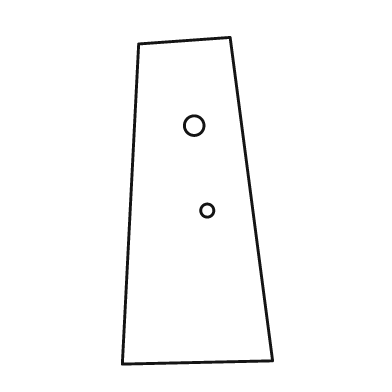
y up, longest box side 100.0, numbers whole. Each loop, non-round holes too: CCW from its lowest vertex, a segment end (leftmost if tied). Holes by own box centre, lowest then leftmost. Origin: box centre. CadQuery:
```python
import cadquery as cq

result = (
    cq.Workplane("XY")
    .moveTo(-23.0, -50.0)
    .lineTo(23.0, -49.0)
    .lineTo(10.0, 50.0)
    .lineTo(-18.0, 48.0)
    .close()
    .moveTo(3.0, -3.0)
    .circle(2.0)
    .moveTo(-1.0, 23.0)
    .circle(3.0)
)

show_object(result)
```